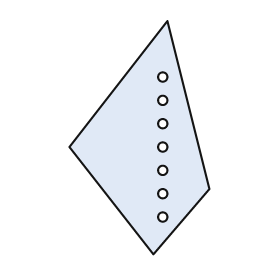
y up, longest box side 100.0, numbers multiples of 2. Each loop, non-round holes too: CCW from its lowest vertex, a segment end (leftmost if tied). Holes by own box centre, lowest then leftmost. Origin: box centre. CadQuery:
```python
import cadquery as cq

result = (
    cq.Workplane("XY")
    .moveTo(6.0, -50.0)
    .lineTo(30.0, -22.0)
    .lineTo(12.0, 50.0)
    .lineTo(-30.0, -4.0)
    .close()
    .moveTo(10.0, -34.0)
    .circle(2.0)
    .moveTo(10.0, -24.0)
    .circle(2.0)
    .moveTo(10.0, -14.0)
    .circle(2.0)
    .moveTo(10.0, -4.0)
    .circle(2.0)
    .moveTo(10.0, 6.0)
    .circle(2.0)
    .moveTo(10.0, 16.0)
    .circle(2.0)
    .moveTo(10.0, 26.0)
    .circle(2.0)
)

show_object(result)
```